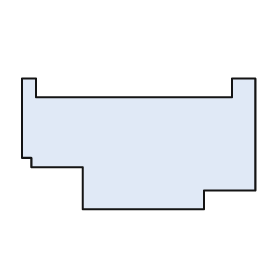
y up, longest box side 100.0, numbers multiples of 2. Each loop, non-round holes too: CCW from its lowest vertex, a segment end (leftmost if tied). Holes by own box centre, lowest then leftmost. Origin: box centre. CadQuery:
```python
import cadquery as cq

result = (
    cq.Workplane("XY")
    .moveTo(-24.0, -28.0)
    .lineTo(28.0, -28.0)
    .lineTo(28.0, -20.0)
    .lineTo(50.0, -20.0)
    .lineTo(50.0, 28.0)
    .lineTo(40.0, 28.0)
    .lineTo(40.0, 20.0)
    .lineTo(-44.0, 20.0)
    .lineTo(-44.0, 28.0)
    .lineTo(-50.0, 28.0)
    .lineTo(-50.0, -6.0)
    .lineTo(-46.0, -6.0)
    .lineTo(-46.0, -10.0)
    .lineTo(-24.0, -10.0)
    .close()
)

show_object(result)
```